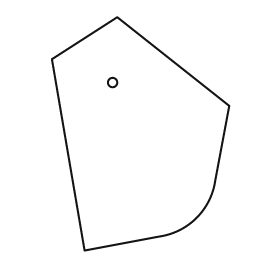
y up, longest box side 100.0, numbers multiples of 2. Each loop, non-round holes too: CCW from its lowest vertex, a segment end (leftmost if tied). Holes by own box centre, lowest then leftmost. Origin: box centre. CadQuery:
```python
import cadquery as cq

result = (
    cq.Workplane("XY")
    .moveTo(-24.0, -50.0)
    .lineTo(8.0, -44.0)
    .threePointArc((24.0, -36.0), (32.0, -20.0))
    .lineTo(38.0, 12.0)
    .lineTo(-10.0, 50.0)
    .lineTo(-38.0, 32.0)
    .close()
    .moveTo(-12.0, 22.0)
    .circle(2.0)
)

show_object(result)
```